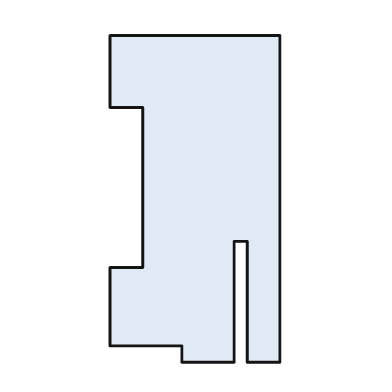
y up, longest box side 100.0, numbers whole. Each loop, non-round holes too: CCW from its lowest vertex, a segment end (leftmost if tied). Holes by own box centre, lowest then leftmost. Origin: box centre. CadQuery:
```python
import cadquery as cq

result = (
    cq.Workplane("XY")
    .moveTo(-4.0, -50.0)
    .lineTo(12.0, -50.0)
    .lineTo(12.0, -13.0)
    .lineTo(16.0, -13.0)
    .lineTo(16.0, -50.0)
    .lineTo(26.0, -50.0)
    .lineTo(26.0, 50.0)
    .lineTo(-26.0, 50.0)
    .lineTo(-26.0, 28.0)
    .lineTo(-16.0, 28.0)
    .lineTo(-16.0, -21.0)
    .lineTo(-26.0, -21.0)
    .lineTo(-26.0, -45.0)
    .lineTo(-4.0, -45.0)
    .close()
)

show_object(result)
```